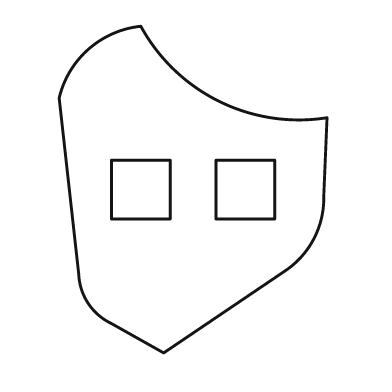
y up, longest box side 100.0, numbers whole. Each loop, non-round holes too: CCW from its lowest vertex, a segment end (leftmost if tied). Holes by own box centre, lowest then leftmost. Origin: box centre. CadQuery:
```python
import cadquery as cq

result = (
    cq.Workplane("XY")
    .moveTo(-9.0, -50.0)
    .lineTo(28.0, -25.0)
    .threePointArc((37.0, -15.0), (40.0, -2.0))
    .lineTo(41.0, 22.0)
    .threePointArc((8.0, 27.0), (-16.0, 50.0))
    .threePointArc((-32.0, 43.0), (-41.0, 28.0))
    .lineTo(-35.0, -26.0)
    .threePointArc((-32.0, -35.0), (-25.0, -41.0))
    .close()
    .moveTo(-25.0, -9.0)
    .lineTo(-7.0, -9.0)
    .lineTo(-7.0, 9.0)
    .lineTo(-25.0, 9.0)
    .close()
    .moveTo(7.0, -9.0)
    .lineTo(25.0, -9.0)
    .lineTo(25.0, 9.0)
    .lineTo(7.0, 9.0)
    .close()
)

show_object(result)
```